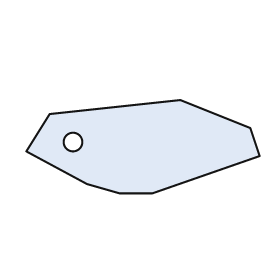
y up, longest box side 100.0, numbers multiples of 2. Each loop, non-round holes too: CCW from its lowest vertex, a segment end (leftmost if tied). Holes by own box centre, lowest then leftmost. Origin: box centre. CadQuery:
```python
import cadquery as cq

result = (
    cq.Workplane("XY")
    .moveTo(-10.0, -20.0)
    .lineTo(4.0, -20.0)
    .lineTo(50.0, -4.0)
    .lineTo(46.0, 8.0)
    .lineTo(16.0, 20.0)
    .lineTo(-40.0, 14.0)
    .lineTo(-50.0, -2.0)
    .lineTo(-24.0, -16.0)
    .close()
    .moveTo(-30.0, 2.0)
    .circle(4.0)
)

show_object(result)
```